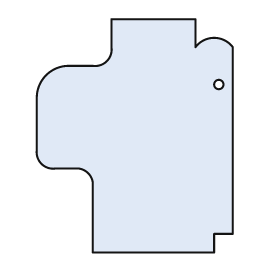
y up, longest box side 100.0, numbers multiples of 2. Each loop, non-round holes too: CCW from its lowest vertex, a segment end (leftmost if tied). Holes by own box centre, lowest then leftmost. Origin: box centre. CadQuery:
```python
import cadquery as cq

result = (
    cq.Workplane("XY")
    .moveTo(-18.0, -50.0)
    .lineTo(34.0, -50.0)
    .lineTo(34.0, -42.0)
    .lineTo(42.0, -42.0)
    .lineTo(42.0, 38.0)
    .threePointArc((34.0, 42.0), (26.0, 38.0))
    .lineTo(26.0, 50.0)
    .lineTo(-10.0, 50.0)
    .lineTo(-10.0, 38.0)
    .threePointArc((-12.0, 32.0), (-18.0, 30.0))
    .lineTo(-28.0, 30.0)
    .threePointArc((-38.0, 26.0), (-42.0, 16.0))
    .lineTo(-42.0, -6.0)
    .threePointArc((-40.0, -12.0), (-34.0, -14.0))
    .lineTo(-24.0, -14.0)
    .threePointArc((-20.0, -16.0), (-18.0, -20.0))
    .close()
    .moveTo(36.0, 22.0)
    .circle(2.0)
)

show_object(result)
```